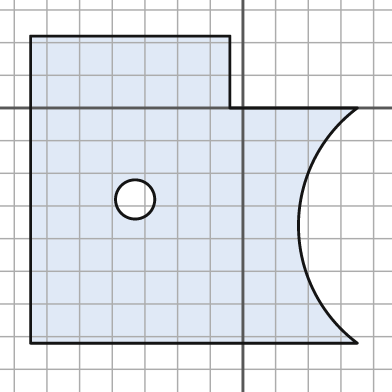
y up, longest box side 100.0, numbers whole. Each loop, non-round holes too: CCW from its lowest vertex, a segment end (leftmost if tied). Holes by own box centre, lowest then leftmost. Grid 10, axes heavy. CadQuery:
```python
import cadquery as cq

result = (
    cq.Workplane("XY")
    .moveTo(-65.0, -72.0)
    .lineTo(35.0, -72.0)
    .threePointArc((17.0, -36.0), (35.0, 0.0))
    .lineTo(-4.0, 0.0)
    .lineTo(-4.0, 22.0)
    .lineTo(-65.0, 22.0)
    .close()
    .moveTo(-33.0, -28.0)
    .circle(6.0)
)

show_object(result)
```